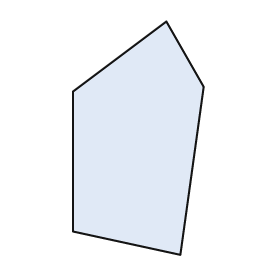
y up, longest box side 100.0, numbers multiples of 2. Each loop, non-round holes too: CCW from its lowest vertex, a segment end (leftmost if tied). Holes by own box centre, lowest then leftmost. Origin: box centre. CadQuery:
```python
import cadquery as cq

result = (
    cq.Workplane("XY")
    .moveTo(18.0, -50.0)
    .lineTo(28.0, 22.0)
    .lineTo(12.0, 50.0)
    .lineTo(-28.0, 20.0)
    .lineTo(-28.0, -40.0)
    .close()
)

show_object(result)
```